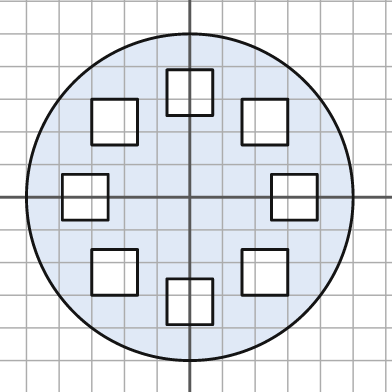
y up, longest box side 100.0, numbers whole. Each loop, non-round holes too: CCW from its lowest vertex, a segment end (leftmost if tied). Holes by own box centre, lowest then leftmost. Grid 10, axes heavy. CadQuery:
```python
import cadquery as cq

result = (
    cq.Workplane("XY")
    .moveTo(0.0, 0.0)
    .circle(50.0)
    .moveTo(-7.0, -39.0)
    .lineTo(7.0, -39.0)
    .lineTo(7.0, -25.0)
    .lineTo(-7.0, -25.0)
    .close()
    .moveTo(-30.0, -30.0)
    .lineTo(-16.0, -30.0)
    .lineTo(-16.0, -16.0)
    .lineTo(-30.0, -16.0)
    .close()
    .moveTo(16.0, -30.0)
    .lineTo(30.0, -30.0)
    .lineTo(30.0, -16.0)
    .lineTo(16.0, -16.0)
    .close()
    .moveTo(-39.0, -7.0)
    .lineTo(-25.0, -7.0)
    .lineTo(-25.0, 7.0)
    .lineTo(-39.0, 7.0)
    .close()
    .moveTo(25.0, -7.0)
    .lineTo(39.0, -7.0)
    .lineTo(39.0, 7.0)
    .lineTo(25.0, 7.0)
    .close()
    .moveTo(-30.0, 16.0)
    .lineTo(-16.0, 16.0)
    .lineTo(-16.0, 30.0)
    .lineTo(-30.0, 30.0)
    .close()
    .moveTo(16.0, 16.0)
    .lineTo(30.0, 16.0)
    .lineTo(30.0, 30.0)
    .lineTo(16.0, 30.0)
    .close()
    .moveTo(-7.0, 25.0)
    .lineTo(7.0, 25.0)
    .lineTo(7.0, 39.0)
    .lineTo(-7.0, 39.0)
    .close()
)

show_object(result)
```